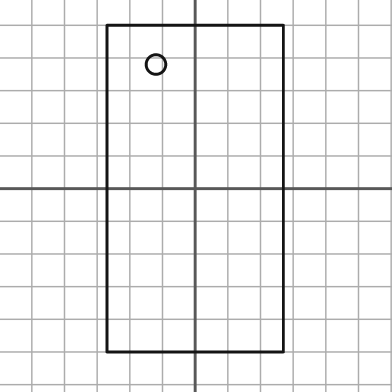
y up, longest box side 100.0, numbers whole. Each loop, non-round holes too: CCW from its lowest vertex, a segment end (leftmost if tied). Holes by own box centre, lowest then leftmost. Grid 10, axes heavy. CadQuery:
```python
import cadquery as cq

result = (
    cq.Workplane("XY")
    .moveTo(-27.0, -50.0)
    .lineTo(27.0, -50.0)
    .lineTo(27.0, 50.0)
    .lineTo(-27.0, 50.0)
    .close()
    .moveTo(-12.0, 38.0)
    .circle(3.0)
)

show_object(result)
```